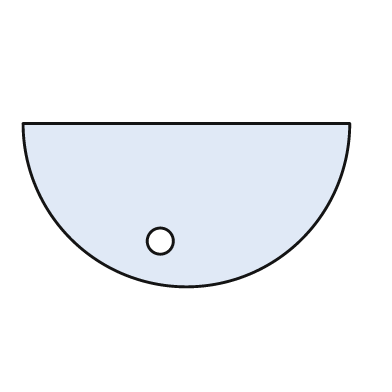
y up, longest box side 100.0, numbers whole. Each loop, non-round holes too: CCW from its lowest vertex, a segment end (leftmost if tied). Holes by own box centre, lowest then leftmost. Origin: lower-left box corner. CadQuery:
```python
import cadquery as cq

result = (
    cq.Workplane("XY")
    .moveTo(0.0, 50.0)
    .threePointArc((50.0, 0.0), (100.0, 50.0))
    .close()
    .moveTo(42.0, 14.0)
    .circle(4.0)
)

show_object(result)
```